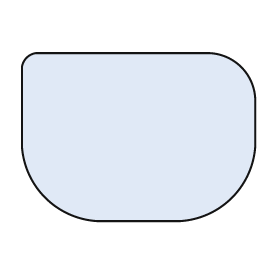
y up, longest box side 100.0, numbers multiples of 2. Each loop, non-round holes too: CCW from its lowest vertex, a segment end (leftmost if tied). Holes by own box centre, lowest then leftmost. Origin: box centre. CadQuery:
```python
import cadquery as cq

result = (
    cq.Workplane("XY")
    .moveTo(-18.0, -36.0)
    .lineTo(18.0, -36.0)
    .threePointArc((40.0, -26.0), (50.0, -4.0))
    .lineTo(50.0, 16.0)
    .threePointArc((44.0, 30.0), (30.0, 36.0))
    .lineTo(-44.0, 36.0)
    .threePointArc((-48.0, 34.0), (-50.0, 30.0))
    .lineTo(-50.0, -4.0)
    .threePointArc((-40.0, -26.0), (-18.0, -36.0))
    .close()
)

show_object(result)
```